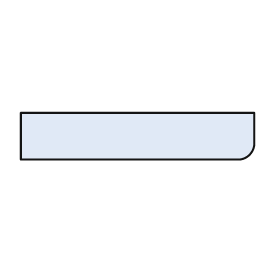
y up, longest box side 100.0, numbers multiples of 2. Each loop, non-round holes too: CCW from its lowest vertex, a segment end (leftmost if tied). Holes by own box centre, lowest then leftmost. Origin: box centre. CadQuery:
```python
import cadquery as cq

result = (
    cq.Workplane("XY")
    .moveTo(-50.0, -10.0)
    .lineTo(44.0, -10.0)
    .threePointArc((48.0, -8.0), (50.0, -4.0))
    .lineTo(50.0, 10.0)
    .lineTo(-50.0, 10.0)
    .close()
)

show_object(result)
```